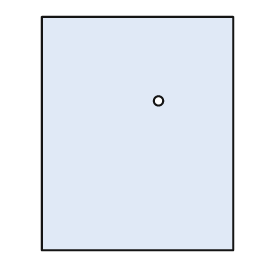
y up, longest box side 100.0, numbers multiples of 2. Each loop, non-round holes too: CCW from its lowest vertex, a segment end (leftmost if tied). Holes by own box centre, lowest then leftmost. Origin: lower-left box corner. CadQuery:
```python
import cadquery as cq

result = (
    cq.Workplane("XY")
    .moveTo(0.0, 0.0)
    .lineTo(82.0, 0.0)
    .lineTo(82.0, 100.0)
    .lineTo(0.0, 100.0)
    .close()
    .moveTo(50.0, 64.0)
    .circle(2.0)
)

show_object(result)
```